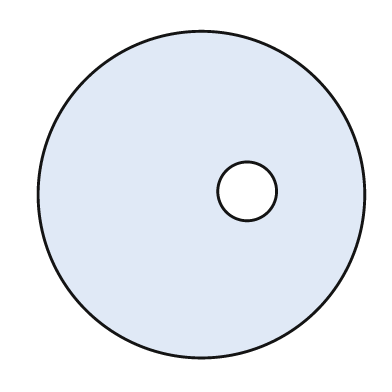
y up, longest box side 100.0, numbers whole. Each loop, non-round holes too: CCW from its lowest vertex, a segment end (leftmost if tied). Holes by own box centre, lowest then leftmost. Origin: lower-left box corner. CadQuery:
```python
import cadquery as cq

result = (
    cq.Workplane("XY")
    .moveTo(50.0, 50.0)
    .circle(50.0)
    .moveTo(64.0, 51.0)
    .circle(9.0)
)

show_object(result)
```